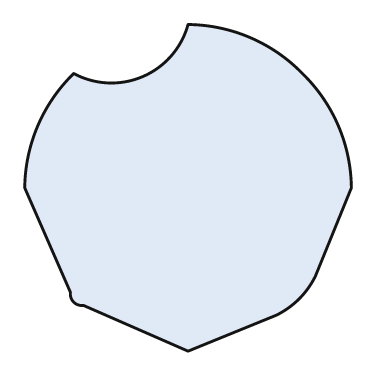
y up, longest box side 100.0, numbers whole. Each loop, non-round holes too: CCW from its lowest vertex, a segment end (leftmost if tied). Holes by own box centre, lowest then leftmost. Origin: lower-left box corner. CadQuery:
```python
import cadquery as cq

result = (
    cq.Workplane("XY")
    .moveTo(50.0, 0.0)
    .lineTo(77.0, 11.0)
    .threePointArc((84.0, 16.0), (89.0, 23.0))
    .lineTo(100.0, 50.0)
    .threePointArc((96.0, 69.0), (85.0, 85.0))
    .threePointArc((69.0, 96.0), (50.0, 100.0))
    .threePointArc((36.0, 84.0), (15.0, 85.0))
    .threePointArc((4.0, 69.0), (0.0, 50.0))
    .lineTo(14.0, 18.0)
    .threePointArc((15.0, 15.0), (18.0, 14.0))
    .close()
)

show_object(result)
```